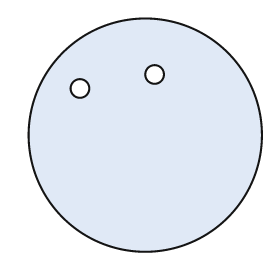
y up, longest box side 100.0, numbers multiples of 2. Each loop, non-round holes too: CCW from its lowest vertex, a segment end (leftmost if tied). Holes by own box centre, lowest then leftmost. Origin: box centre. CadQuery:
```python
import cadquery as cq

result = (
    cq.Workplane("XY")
    .moveTo(0.0, 0.0)
    .circle(50.0)
    .moveTo(-28.0, 20.0)
    .circle(4.0)
    .moveTo(4.0, 26.0)
    .circle(4.0)
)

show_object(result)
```